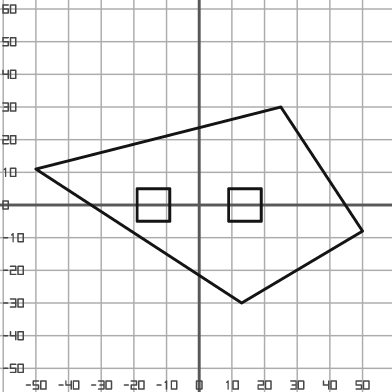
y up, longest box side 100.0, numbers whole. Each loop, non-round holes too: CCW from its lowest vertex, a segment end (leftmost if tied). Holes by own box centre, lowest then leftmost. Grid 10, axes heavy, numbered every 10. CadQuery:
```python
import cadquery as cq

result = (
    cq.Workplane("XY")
    .moveTo(13.0, -30.0)
    .lineTo(50.0, -8.0)
    .lineTo(25.0, 30.0)
    .lineTo(-50.0, 11.0)
    .close()
    .moveTo(-19.0, -5.0)
    .lineTo(-9.0, -5.0)
    .lineTo(-9.0, 5.0)
    .lineTo(-19.0, 5.0)
    .close()
    .moveTo(9.0, -5.0)
    .lineTo(19.0, -5.0)
    .lineTo(19.0, 5.0)
    .lineTo(9.0, 5.0)
    .close()
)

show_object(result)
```